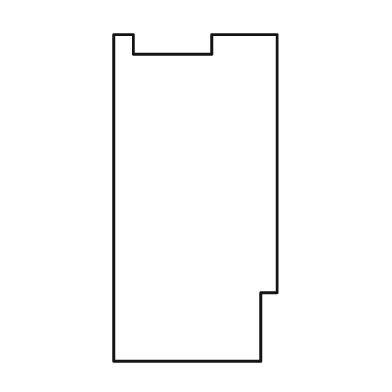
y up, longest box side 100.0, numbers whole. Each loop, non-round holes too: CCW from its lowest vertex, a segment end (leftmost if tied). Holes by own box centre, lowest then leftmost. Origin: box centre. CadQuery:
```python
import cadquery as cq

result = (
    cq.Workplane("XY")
    .moveTo(-25.0, -50.0)
    .lineTo(20.0, -50.0)
    .lineTo(20.0, -29.0)
    .lineTo(25.0, -29.0)
    .lineTo(25.0, 50.0)
    .lineTo(5.0, 50.0)
    .lineTo(5.0, 44.0)
    .lineTo(-19.0, 44.0)
    .lineTo(-19.0, 50.0)
    .lineTo(-25.0, 50.0)
    .close()
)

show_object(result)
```